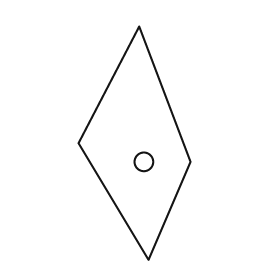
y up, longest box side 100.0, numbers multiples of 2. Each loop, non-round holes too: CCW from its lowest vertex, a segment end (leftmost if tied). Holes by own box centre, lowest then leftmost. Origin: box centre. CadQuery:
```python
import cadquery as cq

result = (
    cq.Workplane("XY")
    .moveTo(6.0, -50.0)
    .lineTo(24.0, -8.0)
    .lineTo(2.0, 50.0)
    .lineTo(-24.0, 0.0)
    .close()
    .moveTo(4.0, -8.0)
    .circle(4.0)
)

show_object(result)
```